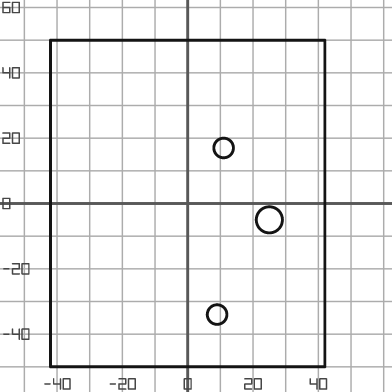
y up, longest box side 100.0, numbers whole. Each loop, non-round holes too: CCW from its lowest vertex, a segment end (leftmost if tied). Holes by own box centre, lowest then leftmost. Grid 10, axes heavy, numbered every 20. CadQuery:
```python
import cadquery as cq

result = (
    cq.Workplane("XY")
    .moveTo(-42.0, -50.0)
    .lineTo(42.0, -50.0)
    .lineTo(42.0, 50.0)
    .lineTo(-42.0, 50.0)
    .close()
    .moveTo(9.0, -34.0)
    .circle(3.0)
    .moveTo(25.0, -5.0)
    .circle(4.0)
    .moveTo(11.0, 17.0)
    .circle(3.0)
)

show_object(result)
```